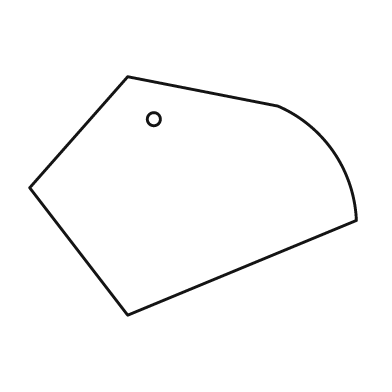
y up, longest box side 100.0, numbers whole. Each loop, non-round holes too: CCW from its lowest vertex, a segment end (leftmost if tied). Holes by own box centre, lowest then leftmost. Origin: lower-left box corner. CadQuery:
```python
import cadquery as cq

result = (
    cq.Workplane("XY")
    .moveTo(30.0, 0.0)
    .lineTo(100.0, 29.0)
    .threePointArc((93.0, 50.0), (76.0, 64.0))
    .lineTo(30.0, 73.0)
    .lineTo(0.0, 39.0)
    .close()
    .moveTo(38.0, 60.0)
    .circle(2.0)
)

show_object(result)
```